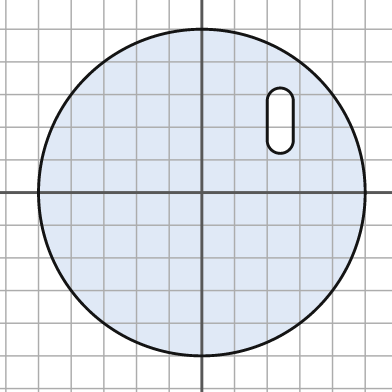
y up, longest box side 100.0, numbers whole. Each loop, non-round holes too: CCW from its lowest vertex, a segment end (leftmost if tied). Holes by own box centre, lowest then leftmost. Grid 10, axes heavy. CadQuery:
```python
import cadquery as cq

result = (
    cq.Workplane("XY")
    .moveTo(0.0, 0.0)
    .circle(50.0)
    .moveTo(20.0, 16.0)
    .threePointArc((24.0, 12.0), (28.0, 16.0))
    .lineTo(28.0, 28.0)
    .threePointArc((24.0, 32.0), (20.0, 28.0))
    .close()
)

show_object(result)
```